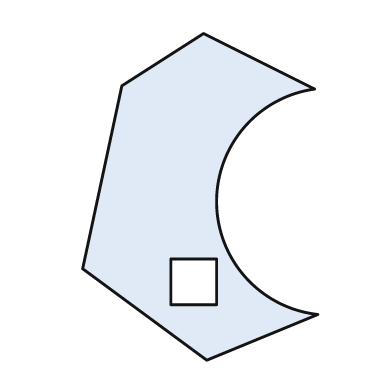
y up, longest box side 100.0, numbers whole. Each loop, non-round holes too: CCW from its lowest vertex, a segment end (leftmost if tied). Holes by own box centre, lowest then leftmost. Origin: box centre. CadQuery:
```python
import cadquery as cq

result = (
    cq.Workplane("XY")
    .moveTo(2.0, -50.0)
    .lineTo(36.0, -36.0)
    .threePointArc((5.0, -2.0), (35.0, 33.0))
    .lineTo(1.0, 50.0)
    .lineTo(-24.0, 34.0)
    .lineTo(-36.0, -22.0)
    .close()
    .moveTo(-9.0, -33.0)
    .lineTo(5.0, -33.0)
    .lineTo(5.0, -19.0)
    .lineTo(-9.0, -19.0)
    .close()
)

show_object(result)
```